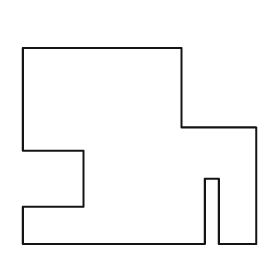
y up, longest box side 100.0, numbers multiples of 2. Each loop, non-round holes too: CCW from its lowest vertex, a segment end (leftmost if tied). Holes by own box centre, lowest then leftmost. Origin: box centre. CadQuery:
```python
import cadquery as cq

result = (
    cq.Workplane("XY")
    .moveTo(-50.0, -42.0)
    .lineTo(28.0, -42.0)
    .lineTo(28.0, -14.0)
    .lineTo(34.0, -14.0)
    .lineTo(34.0, -42.0)
    .lineTo(50.0, -42.0)
    .lineTo(50.0, 8.0)
    .lineTo(18.0, 8.0)
    .lineTo(18.0, 42.0)
    .lineTo(-50.0, 42.0)
    .lineTo(-50.0, -2.0)
    .lineTo(-24.0, -2.0)
    .lineTo(-24.0, -26.0)
    .lineTo(-50.0, -26.0)
    .close()
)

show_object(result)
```